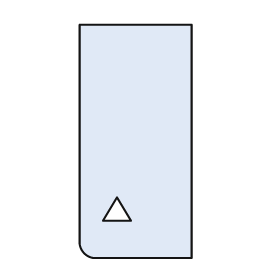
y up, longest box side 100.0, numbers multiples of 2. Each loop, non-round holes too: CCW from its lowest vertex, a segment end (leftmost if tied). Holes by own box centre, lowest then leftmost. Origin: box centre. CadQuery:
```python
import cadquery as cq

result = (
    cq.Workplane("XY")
    .moveTo(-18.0, -50.0)
    .lineTo(24.0, -50.0)
    .lineTo(24.0, 50.0)
    .lineTo(-24.0, 50.0)
    .lineTo(-24.0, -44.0)
    .threePointArc((-22.0, -48.0), (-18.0, -50.0))
    .close()
    .moveTo(-14.0, -34.0)
    .lineTo(-2.0, -34.0)
    .lineTo(-8.0, -24.0)
    .close()
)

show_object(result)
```